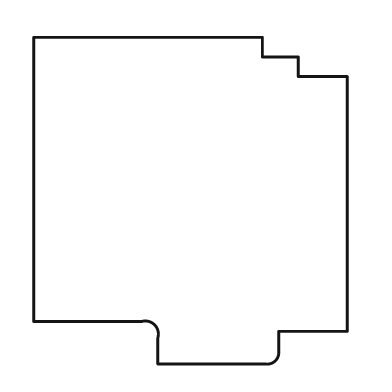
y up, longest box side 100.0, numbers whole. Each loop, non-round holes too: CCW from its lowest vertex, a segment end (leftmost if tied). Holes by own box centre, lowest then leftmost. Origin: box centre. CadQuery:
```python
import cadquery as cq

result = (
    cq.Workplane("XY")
    .moveTo(-10.0, -50.0)
    .lineTo(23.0, -50.0)
    .threePointArc((26.0, -49.0), (27.0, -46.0))
    .lineTo(27.0, -40.0)
    .lineTo(48.0, -40.0)
    .lineTo(48.0, 38.0)
    .lineTo(33.0, 38.0)
    .lineTo(33.0, 44.0)
    .lineTo(22.0, 44.0)
    .lineTo(22.0, 50.0)
    .lineTo(-48.0, 50.0)
    .lineTo(-48.0, -37.0)
    .lineTo(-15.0, -37.0)
    .threePointArc((-11.0, -38.0), (-10.0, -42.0))
    .close()
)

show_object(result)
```